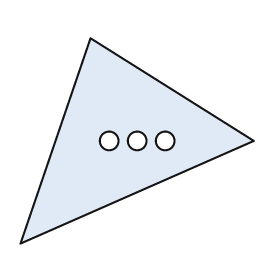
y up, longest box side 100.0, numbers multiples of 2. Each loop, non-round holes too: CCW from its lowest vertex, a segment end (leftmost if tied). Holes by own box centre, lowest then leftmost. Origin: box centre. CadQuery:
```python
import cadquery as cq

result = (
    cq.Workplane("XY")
    .moveTo(-50.0, -44.0)
    .lineTo(50.0, 0.0)
    .lineTo(-20.0, 44.0)
    .close()
    .moveTo(-12.0, 0.0)
    .circle(4.0)
    .moveTo(0.0, 0.0)
    .circle(4.0)
    .moveTo(12.0, 0.0)
    .circle(4.0)
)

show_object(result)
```